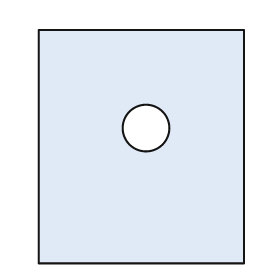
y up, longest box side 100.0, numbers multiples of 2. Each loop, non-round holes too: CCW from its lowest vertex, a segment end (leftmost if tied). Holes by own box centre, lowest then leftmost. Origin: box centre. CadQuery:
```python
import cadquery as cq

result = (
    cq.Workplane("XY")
    .moveTo(-44.0, -50.0)
    .lineTo(44.0, -50.0)
    .lineTo(44.0, 50.0)
    .lineTo(-44.0, 50.0)
    .close()
    .moveTo(2.0, 8.0)
    .circle(10.0)
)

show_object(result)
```